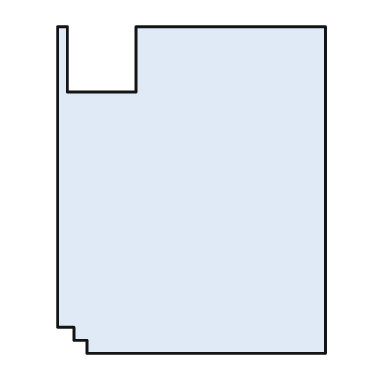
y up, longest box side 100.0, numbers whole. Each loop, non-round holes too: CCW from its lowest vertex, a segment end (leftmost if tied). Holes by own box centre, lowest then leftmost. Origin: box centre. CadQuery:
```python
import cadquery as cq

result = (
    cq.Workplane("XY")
    .moveTo(-32.0, -50.0)
    .lineTo(41.0, -50.0)
    .lineTo(41.0, 50.0)
    .lineTo(-17.0, 50.0)
    .lineTo(-17.0, 30.0)
    .lineTo(-38.0, 30.0)
    .lineTo(-38.0, 50.0)
    .lineTo(-41.0, 50.0)
    .lineTo(-41.0, -42.0)
    .lineTo(-36.0, -42.0)
    .lineTo(-36.0, -46.0)
    .lineTo(-32.0, -46.0)
    .close()
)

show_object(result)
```